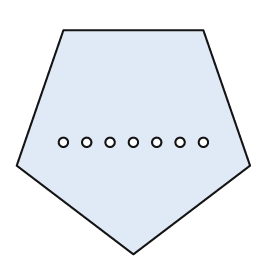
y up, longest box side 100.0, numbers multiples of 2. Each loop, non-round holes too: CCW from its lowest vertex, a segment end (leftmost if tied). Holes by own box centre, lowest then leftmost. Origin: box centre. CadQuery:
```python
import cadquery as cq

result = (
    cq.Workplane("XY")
    .moveTo(0.0, -48.0)
    .lineTo(50.0, -10.0)
    .lineTo(30.0, 48.0)
    .lineTo(-30.0, 48.0)
    .lineTo(-50.0, -10.0)
    .close()
    .moveTo(-30.0, 0.0)
    .circle(2.0)
    .moveTo(-20.0, 0.0)
    .circle(2.0)
    .moveTo(-10.0, 0.0)
    .circle(2.0)
    .moveTo(0.0, 0.0)
    .circle(2.0)
    .moveTo(10.0, 0.0)
    .circle(2.0)
    .moveTo(20.0, 0.0)
    .circle(2.0)
    .moveTo(30.0, 0.0)
    .circle(2.0)
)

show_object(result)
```